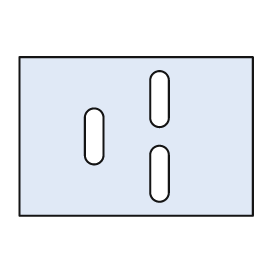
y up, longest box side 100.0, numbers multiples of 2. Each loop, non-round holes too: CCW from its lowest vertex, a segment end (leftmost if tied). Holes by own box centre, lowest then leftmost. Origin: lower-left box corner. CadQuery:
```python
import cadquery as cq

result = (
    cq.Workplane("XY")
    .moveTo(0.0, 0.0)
    .lineTo(100.0, 0.0)
    .lineTo(100.0, 68.0)
    .lineTo(0.0, 68.0)
    .close()
    .moveTo(56.0, 10.0)
    .threePointArc((60.0, 6.0), (64.0, 10.0))
    .lineTo(64.0, 26.0)
    .threePointArc((60.0, 30.0), (56.0, 26.0))
    .close()
    .moveTo(28.0, 26.0)
    .threePointArc((32.0, 22.0), (36.0, 26.0))
    .lineTo(36.0, 42.0)
    .threePointArc((32.0, 46.0), (28.0, 42.0))
    .close()
    .moveTo(56.0, 42.0)
    .threePointArc((60.0, 38.0), (64.0, 42.0))
    .lineTo(64.0, 58.0)
    .threePointArc((60.0, 62.0), (56.0, 58.0))
    .close()
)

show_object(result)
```